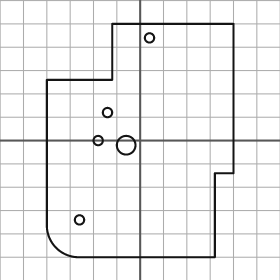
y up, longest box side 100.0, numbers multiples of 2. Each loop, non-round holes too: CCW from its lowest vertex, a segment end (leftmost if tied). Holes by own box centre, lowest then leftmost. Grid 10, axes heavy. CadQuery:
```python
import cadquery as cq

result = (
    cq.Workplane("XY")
    .moveTo(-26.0, -50.0)
    .lineTo(32.0, -50.0)
    .lineTo(32.0, -14.0)
    .lineTo(40.0, -14.0)
    .lineTo(40.0, 50.0)
    .lineTo(-12.0, 50.0)
    .lineTo(-12.0, 26.0)
    .lineTo(-40.0, 26.0)
    .lineTo(-40.0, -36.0)
    .threePointArc((-36.0, -46.0), (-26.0, -50.0))
    .close()
    .moveTo(-26.0, -34.0)
    .circle(2.0)
    .moveTo(-6.0, -2.0)
    .circle(4.0)
    .moveTo(-18.0, 0.0)
    .circle(2.0)
    .moveTo(-14.0, 12.0)
    .circle(2.0)
    .moveTo(4.0, 44.0)
    .circle(2.0)
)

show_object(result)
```